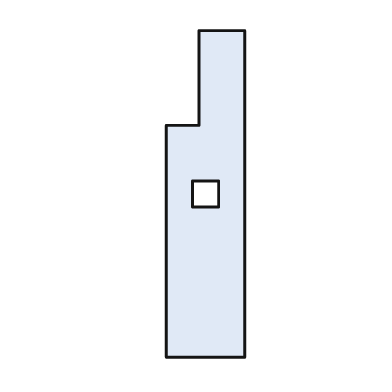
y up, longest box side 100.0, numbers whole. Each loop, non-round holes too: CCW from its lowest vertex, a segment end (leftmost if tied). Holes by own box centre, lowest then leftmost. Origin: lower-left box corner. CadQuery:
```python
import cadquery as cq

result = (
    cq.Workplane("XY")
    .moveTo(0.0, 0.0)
    .lineTo(24.0, 0.0)
    .lineTo(24.0, 100.0)
    .lineTo(10.0, 100.0)
    .lineTo(10.0, 71.0)
    .lineTo(0.0, 71.0)
    .close()
    .moveTo(8.0, 46.0)
    .lineTo(16.0, 46.0)
    .lineTo(16.0, 54.0)
    .lineTo(8.0, 54.0)
    .close()
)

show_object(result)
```